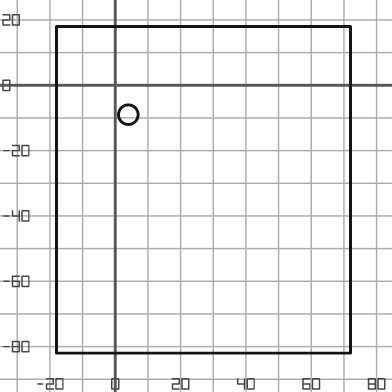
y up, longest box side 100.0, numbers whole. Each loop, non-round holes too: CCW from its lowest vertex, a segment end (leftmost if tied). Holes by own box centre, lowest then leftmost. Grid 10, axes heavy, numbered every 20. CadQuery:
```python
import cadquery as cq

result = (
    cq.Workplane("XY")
    .moveTo(-18.0, -82.0)
    .lineTo(72.0, -82.0)
    .lineTo(72.0, 18.0)
    .lineTo(-18.0, 18.0)
    .close()
    .moveTo(4.0, -9.0)
    .circle(3.0)
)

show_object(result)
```